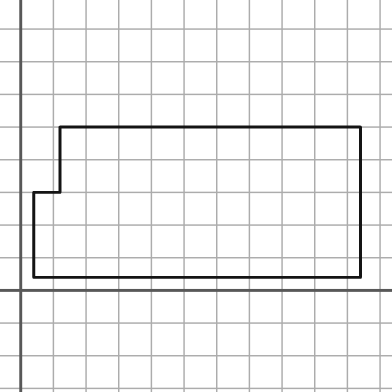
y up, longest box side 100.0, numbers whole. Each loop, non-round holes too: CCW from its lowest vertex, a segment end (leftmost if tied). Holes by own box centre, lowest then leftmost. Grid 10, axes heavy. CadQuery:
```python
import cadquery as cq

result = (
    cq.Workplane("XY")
    .moveTo(4.0, 4.0)
    .lineTo(104.0, 4.0)
    .lineTo(104.0, 50.0)
    .lineTo(12.0, 50.0)
    .lineTo(12.0, 30.0)
    .lineTo(4.0, 30.0)
    .close()
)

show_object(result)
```